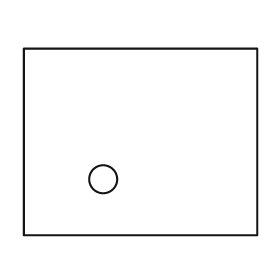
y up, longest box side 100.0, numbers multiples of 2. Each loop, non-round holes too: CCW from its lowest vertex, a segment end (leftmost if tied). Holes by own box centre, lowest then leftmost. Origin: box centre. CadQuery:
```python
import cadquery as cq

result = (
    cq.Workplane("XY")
    .moveTo(-50.0, -40.0)
    .lineTo(50.0, -40.0)
    .lineTo(50.0, 40.0)
    .lineTo(-50.0, 40.0)
    .close()
    .moveTo(-16.0, -16.0)
    .circle(6.0)
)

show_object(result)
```